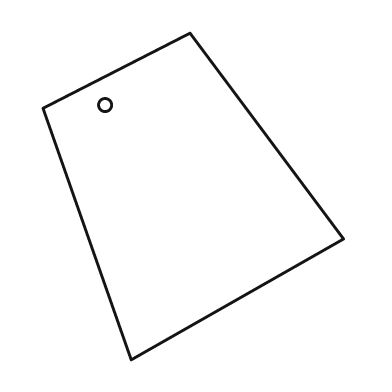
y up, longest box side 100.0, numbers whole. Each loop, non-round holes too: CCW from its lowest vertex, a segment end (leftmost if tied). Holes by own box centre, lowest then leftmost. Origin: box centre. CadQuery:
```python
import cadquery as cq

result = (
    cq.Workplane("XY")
    .moveTo(-19.0, -50.0)
    .lineTo(46.0, -13.0)
    .lineTo(-1.0, 50.0)
    .lineTo(-46.0, 27.0)
    .close()
    .moveTo(-27.0, 28.0)
    .circle(2.0)
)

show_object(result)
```